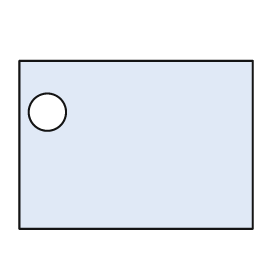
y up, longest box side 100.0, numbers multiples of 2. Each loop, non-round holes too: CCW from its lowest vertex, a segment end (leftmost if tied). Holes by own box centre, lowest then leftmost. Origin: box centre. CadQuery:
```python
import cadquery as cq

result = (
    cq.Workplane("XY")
    .moveTo(-50.0, -36.0)
    .lineTo(50.0, -36.0)
    .lineTo(50.0, 36.0)
    .lineTo(-50.0, 36.0)
    .close()
    .moveTo(-38.0, 14.0)
    .circle(8.0)
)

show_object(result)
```